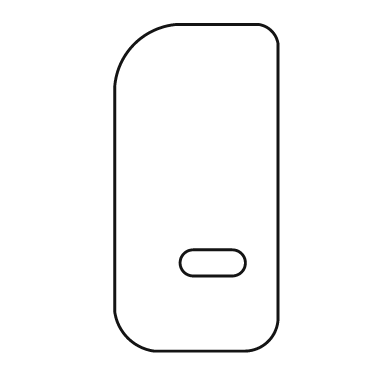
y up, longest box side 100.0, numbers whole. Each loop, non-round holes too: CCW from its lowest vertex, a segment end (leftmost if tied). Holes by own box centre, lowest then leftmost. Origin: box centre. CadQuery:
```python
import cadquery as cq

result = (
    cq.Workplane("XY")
    .moveTo(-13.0, -50.0)
    .lineTo(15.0, -50.0)
    .threePointArc((22.0, -47.0), (25.0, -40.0))
    .lineTo(25.0, 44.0)
    .threePointArc((23.0, 48.0), (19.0, 50.0))
    .lineTo(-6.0, 50.0)
    .threePointArc((-19.0, 44.0), (-25.0, 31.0))
    .lineTo(-25.0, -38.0)
    .threePointArc((-21.0, -46.0), (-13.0, -50.0))
    .close()
    .moveTo(-1.0, -27.0)
    .lineTo(11.0, -27.0)
    .threePointArc((15.0, -23.0), (11.0, -19.0))
    .lineTo(-1.0, -19.0)
    .threePointArc((-5.0, -23.0), (-1.0, -27.0))
    .close()
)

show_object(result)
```